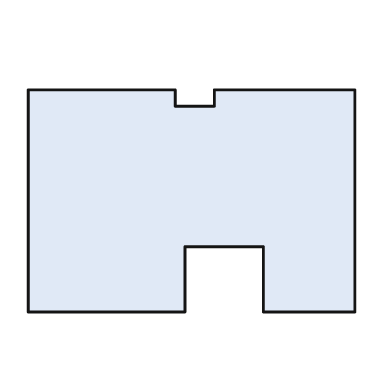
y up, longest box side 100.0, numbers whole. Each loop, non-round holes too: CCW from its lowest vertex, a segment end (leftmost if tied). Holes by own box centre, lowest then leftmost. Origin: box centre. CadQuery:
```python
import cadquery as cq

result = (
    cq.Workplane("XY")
    .moveTo(-50.0, -34.0)
    .lineTo(-2.0, -34.0)
    .lineTo(-2.0, -14.0)
    .lineTo(22.0, -14.0)
    .lineTo(22.0, -34.0)
    .lineTo(50.0, -34.0)
    .lineTo(50.0, 34.0)
    .lineTo(7.0, 34.0)
    .lineTo(7.0, 29.0)
    .lineTo(-5.0, 29.0)
    .lineTo(-5.0, 34.0)
    .lineTo(-50.0, 34.0)
    .close()
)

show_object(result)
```